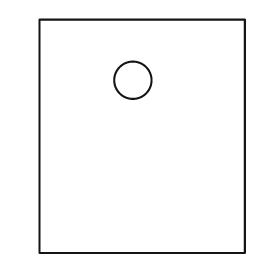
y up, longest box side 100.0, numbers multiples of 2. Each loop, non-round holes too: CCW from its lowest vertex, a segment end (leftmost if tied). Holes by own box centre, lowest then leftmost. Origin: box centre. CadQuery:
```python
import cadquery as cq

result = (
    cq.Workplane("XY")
    .moveTo(-44.0, -50.0)
    .lineTo(44.0, -50.0)
    .lineTo(44.0, 50.0)
    .lineTo(-44.0, 50.0)
    .close()
    .moveTo(-4.0, 24.0)
    .circle(8.0)
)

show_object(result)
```